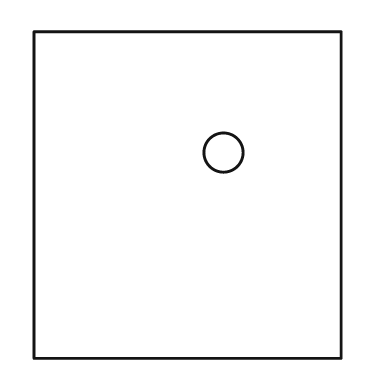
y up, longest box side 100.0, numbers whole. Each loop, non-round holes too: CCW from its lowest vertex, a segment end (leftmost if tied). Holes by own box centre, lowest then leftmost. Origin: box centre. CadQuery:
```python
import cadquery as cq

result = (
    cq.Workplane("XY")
    .moveTo(-47.0, -50.0)
    .lineTo(47.0, -50.0)
    .lineTo(47.0, 50.0)
    .lineTo(-47.0, 50.0)
    .close()
    .moveTo(11.0, 13.0)
    .circle(6.0)
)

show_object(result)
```